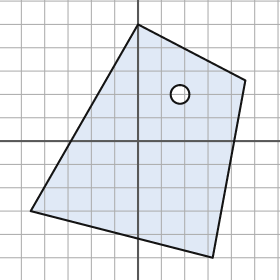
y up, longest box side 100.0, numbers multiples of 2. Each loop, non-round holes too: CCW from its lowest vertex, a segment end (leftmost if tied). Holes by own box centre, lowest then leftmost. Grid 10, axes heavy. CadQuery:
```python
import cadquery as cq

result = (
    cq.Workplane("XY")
    .moveTo(32.0, -50.0)
    .lineTo(46.0, 26.0)
    .lineTo(0.0, 50.0)
    .lineTo(-46.0, -30.0)
    .close()
    .moveTo(18.0, 20.0)
    .circle(4.0)
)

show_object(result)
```